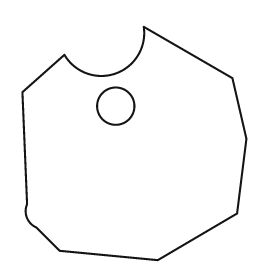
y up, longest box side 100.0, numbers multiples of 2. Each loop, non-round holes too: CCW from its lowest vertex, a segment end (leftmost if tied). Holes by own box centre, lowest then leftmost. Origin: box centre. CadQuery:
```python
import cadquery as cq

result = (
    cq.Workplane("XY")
    .moveTo(10.0, -50.0)
    .lineTo(44.0, -30.0)
    .lineTo(48.0, 2.0)
    .lineTo(42.0, 28.0)
    .lineTo(4.0, 50.0)
    .threePointArc((-8.0, 30.0), (-30.0, 38.0))
    .lineTo(-48.0, 22.0)
    .lineTo(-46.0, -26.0)
    .threePointArc((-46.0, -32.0), (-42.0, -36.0))
    .lineTo(-32.0, -46.0)
    .close()
    .moveTo(-8.0, 16.0)
    .circle(8.0)
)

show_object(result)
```